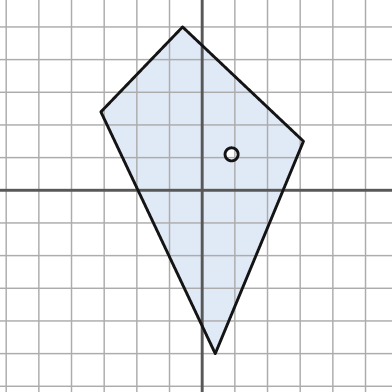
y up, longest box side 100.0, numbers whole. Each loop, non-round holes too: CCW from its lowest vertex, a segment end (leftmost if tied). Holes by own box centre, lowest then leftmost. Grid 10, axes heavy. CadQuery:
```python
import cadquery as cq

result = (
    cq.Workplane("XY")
    .moveTo(4.0, -50.0)
    .lineTo(31.0, 15.0)
    .lineTo(-6.0, 50.0)
    .lineTo(-31.0, 24.0)
    .close()
    .moveTo(9.0, 11.0)
    .circle(2.0)
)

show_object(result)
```